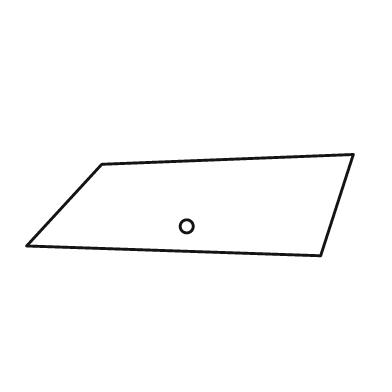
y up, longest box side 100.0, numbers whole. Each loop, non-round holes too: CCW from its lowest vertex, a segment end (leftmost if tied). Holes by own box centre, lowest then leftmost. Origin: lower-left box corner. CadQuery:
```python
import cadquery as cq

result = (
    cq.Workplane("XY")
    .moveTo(90.0, 0.0)
    .lineTo(100.0, 31.0)
    .lineTo(23.0, 28.0)
    .lineTo(0.0, 3.0)
    .close()
    .moveTo(49.0, 9.0)
    .circle(2.0)
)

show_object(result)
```